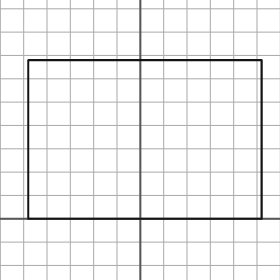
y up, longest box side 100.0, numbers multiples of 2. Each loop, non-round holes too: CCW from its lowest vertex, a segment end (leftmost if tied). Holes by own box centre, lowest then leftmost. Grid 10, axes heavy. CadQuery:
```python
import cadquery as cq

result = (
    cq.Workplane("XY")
    .moveTo(-48.0, 0.0)
    .lineTo(52.0, 0.0)
    .lineTo(52.0, 68.0)
    .lineTo(-48.0, 68.0)
    .close()
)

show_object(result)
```